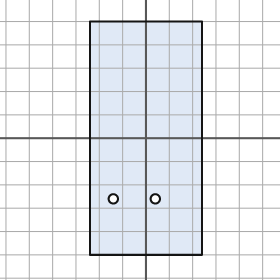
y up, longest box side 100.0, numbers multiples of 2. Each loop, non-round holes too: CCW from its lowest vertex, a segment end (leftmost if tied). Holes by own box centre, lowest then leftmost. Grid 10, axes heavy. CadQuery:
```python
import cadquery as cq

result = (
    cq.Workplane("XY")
    .moveTo(-24.0, -50.0)
    .lineTo(24.0, -50.0)
    .lineTo(24.0, 50.0)
    .lineTo(-24.0, 50.0)
    .close()
    .moveTo(-14.0, -26.0)
    .circle(2.0)
    .moveTo(4.0, -26.0)
    .circle(2.0)
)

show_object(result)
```